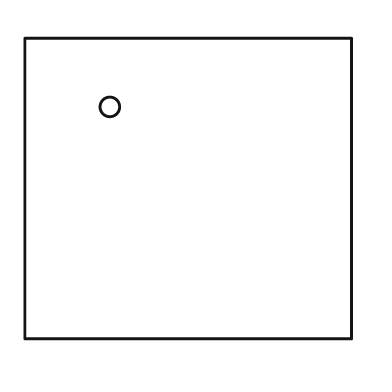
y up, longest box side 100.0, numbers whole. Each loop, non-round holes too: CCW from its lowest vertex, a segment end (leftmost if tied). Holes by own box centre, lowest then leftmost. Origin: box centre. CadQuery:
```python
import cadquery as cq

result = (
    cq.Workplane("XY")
    .moveTo(-50.0, -46.0)
    .lineTo(50.0, -46.0)
    .lineTo(50.0, 46.0)
    .lineTo(-50.0, 46.0)
    .close()
    .moveTo(-24.0, 25.0)
    .circle(3.0)
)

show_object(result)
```